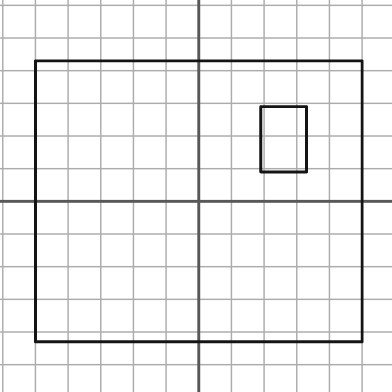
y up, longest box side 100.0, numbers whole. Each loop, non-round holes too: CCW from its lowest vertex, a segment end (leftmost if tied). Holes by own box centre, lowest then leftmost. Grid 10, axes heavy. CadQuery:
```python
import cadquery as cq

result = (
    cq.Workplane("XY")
    .moveTo(-50.0, -43.0)
    .lineTo(50.0, -43.0)
    .lineTo(50.0, 43.0)
    .lineTo(-50.0, 43.0)
    .close()
    .moveTo(19.0, 9.0)
    .lineTo(33.0, 9.0)
    .lineTo(33.0, 29.0)
    .lineTo(19.0, 29.0)
    .close()
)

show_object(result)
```